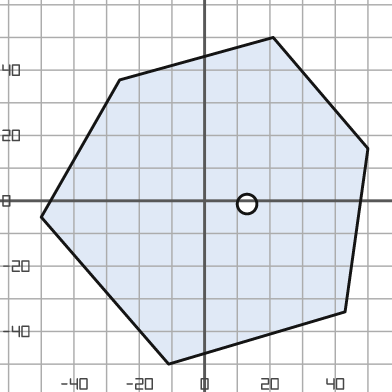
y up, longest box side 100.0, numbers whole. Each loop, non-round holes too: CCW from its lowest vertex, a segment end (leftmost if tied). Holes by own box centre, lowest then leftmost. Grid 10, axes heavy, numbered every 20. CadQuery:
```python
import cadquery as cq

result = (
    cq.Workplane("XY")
    .moveTo(-11.0, -50.0)
    .lineTo(43.0, -34.0)
    .lineTo(50.0, 16.0)
    .lineTo(21.0, 50.0)
    .lineTo(-26.0, 37.0)
    .lineTo(-50.0, -5.0)
    .close()
    .moveTo(13.0, -1.0)
    .circle(3.0)
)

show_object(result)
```